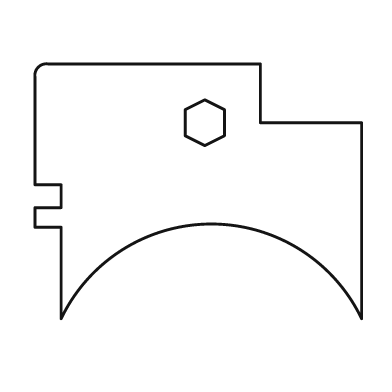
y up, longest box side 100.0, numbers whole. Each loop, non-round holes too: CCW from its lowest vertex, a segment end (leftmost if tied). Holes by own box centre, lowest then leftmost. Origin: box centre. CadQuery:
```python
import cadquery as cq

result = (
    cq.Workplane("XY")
    .moveTo(-42.0, -39.0)
    .threePointArc((4.0, -10.0), (50.0, -39.0))
    .lineTo(50.0, 21.0)
    .lineTo(19.0, 21.0)
    .lineTo(19.0, 39.0)
    .lineTo(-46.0, 39.0)
    .threePointArc((-49.0, 38.0), (-50.0, 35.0))
    .lineTo(-50.0, 2.0)
    .lineTo(-42.0, 2.0)
    .lineTo(-42.0, -5.0)
    .lineTo(-50.0, -5.0)
    .lineTo(-50.0, -11.0)
    .lineTo(-42.0, -11.0)
    .close()
    .moveTo(2.0, 14.0)
    .lineTo(8.0, 17.0)
    .lineTo(8.0, 25.0)
    .lineTo(2.0, 28.0)
    .lineTo(-4.0, 25.0)
    .lineTo(-4.0, 17.0)
    .close()
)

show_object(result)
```